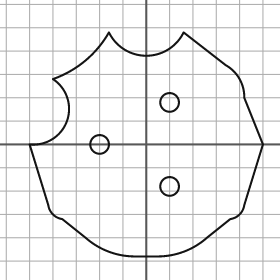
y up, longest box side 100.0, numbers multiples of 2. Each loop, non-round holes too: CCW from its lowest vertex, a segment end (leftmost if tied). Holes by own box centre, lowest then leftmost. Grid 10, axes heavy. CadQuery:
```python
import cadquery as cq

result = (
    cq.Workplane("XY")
    .moveTo(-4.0, -48.0)
    .lineTo(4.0, -48.0)
    .threePointArc((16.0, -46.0), (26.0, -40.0))
    .lineTo(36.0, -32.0)
    .threePointArc((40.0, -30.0), (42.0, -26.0))
    .lineTo(50.0, 0.0)
    .lineTo(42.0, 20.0)
    .threePointArc((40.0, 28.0), (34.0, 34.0))
    .lineTo(16.0, 48.0)
    .threePointArc((0.0, 38.0), (-16.0, 48.0))
    .threePointArc((-26.0, 36.0), (-40.0, 28.0))
    .threePointArc((-34.0, 10.0), (-50.0, 0.0))
    .lineTo(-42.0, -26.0)
    .threePointArc((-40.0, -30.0), (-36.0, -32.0))
    .lineTo(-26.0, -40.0)
    .threePointArc((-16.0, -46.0), (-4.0, -48.0))
    .close()
    .moveTo(10.0, -18.0)
    .circle(4.0)
    .moveTo(-20.0, 0.0)
    .circle(4.0)
    .moveTo(10.0, 18.0)
    .circle(4.0)
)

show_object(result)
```